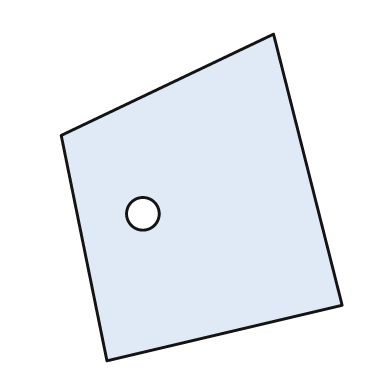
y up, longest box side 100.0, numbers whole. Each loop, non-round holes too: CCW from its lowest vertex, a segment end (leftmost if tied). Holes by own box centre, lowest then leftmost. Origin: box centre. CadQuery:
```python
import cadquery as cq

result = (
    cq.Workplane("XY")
    .moveTo(-29.0, -50.0)
    .lineTo(43.0, -33.0)
    .lineTo(22.0, 50.0)
    .lineTo(-43.0, 19.0)
    .close()
    .moveTo(-18.0, -5.0)
    .circle(5.0)
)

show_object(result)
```